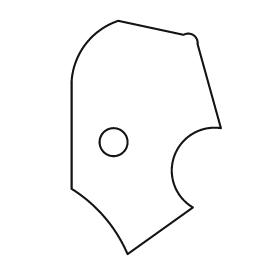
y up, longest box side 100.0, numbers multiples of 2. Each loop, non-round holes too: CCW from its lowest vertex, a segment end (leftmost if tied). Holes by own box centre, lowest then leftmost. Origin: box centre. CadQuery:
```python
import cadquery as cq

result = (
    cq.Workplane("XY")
    .moveTo(-8.0, -50.0)
    .lineTo(20.0, -30.0)
    .threePointArc((12.0, -8.0), (32.0, 4.0))
    .lineTo(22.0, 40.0)
    .threePointArc((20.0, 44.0), (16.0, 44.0))
    .lineTo(-12.0, 50.0)
    .threePointArc((-26.0, 40.0), (-32.0, 24.0))
    .lineTo(-32.0, -22.0)
    .threePointArc((-18.0, -34.0), (-8.0, -50.0))
    .close()
    .moveTo(-14.0, -2.0)
    .circle(6.0)
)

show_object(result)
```